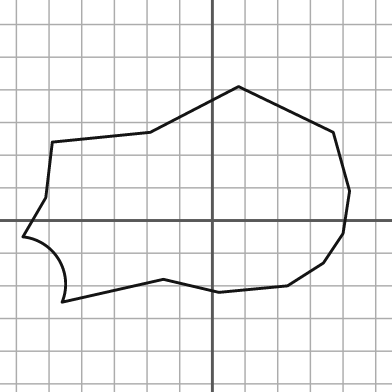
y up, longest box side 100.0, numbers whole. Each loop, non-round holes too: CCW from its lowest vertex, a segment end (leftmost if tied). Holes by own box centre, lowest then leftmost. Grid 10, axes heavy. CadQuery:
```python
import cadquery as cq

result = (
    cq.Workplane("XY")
    .moveTo(-46.0, -25.0)
    .lineTo(-15.0, -18.0)
    .lineTo(2.0, -22.0)
    .lineTo(23.0, -20.0)
    .lineTo(34.0, -13.0)
    .lineTo(40.0, -4.0)
    .lineTo(42.0, 9.0)
    .lineTo(37.0, 27.0)
    .lineTo(8.0, 41.0)
    .lineTo(-19.0, 27.0)
    .lineTo(-49.0, 24.0)
    .lineTo(-51.0, 7.0)
    .lineTo(-58.0, -5.0)
    .threePointArc((-47.0, -12.0), (-46.0, -25.0))
    .close()
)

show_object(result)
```